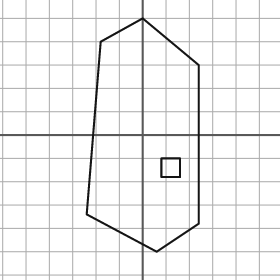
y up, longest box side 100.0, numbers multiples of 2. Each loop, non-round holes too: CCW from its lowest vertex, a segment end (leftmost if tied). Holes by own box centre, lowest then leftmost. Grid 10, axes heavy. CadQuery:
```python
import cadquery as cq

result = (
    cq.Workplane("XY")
    .moveTo(6.0, -50.0)
    .lineTo(24.0, -38.0)
    .lineTo(24.0, 30.0)
    .lineTo(0.0, 50.0)
    .lineTo(-18.0, 40.0)
    .lineTo(-24.0, -34.0)
    .close()
    .moveTo(8.0, -18.0)
    .lineTo(16.0, -18.0)
    .lineTo(16.0, -10.0)
    .lineTo(8.0, -10.0)
    .close()
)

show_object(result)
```